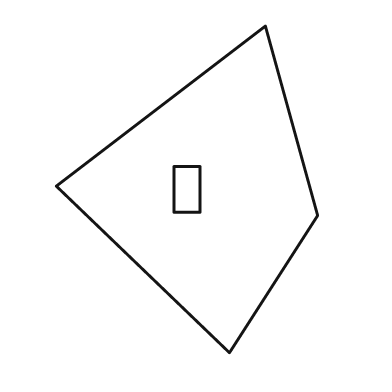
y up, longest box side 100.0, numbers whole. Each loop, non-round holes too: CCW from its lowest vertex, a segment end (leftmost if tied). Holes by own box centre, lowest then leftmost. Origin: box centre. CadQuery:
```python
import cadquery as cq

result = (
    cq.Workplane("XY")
    .moveTo(13.0, -50.0)
    .lineTo(40.0, -8.0)
    .lineTo(24.0, 50.0)
    .lineTo(-40.0, 1.0)
    .close()
    .moveTo(-4.0, -7.0)
    .lineTo(4.0, -7.0)
    .lineTo(4.0, 7.0)
    .lineTo(-4.0, 7.0)
    .close()
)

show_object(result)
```